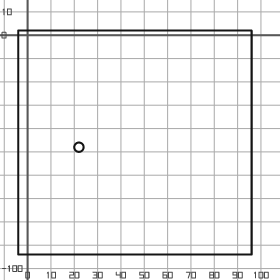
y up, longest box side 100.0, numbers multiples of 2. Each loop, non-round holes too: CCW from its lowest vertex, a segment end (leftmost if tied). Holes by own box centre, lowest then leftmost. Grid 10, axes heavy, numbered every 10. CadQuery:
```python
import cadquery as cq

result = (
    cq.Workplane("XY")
    .moveTo(-4.0, -94.0)
    .lineTo(96.0, -94.0)
    .lineTo(96.0, 2.0)
    .lineTo(-4.0, 2.0)
    .close()
    .moveTo(22.0, -48.0)
    .circle(2.0)
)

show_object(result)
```